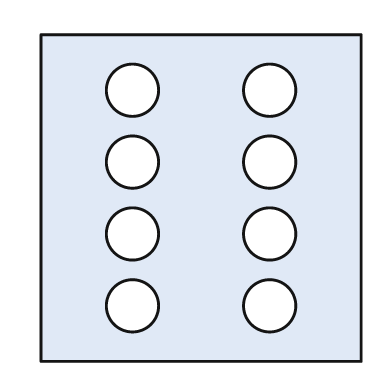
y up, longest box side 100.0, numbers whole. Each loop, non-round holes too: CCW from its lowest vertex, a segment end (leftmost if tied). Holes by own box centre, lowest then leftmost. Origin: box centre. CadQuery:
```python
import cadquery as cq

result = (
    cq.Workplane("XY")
    .moveTo(-49.0, -50.0)
    .lineTo(49.0, -50.0)
    .lineTo(49.0, 50.0)
    .lineTo(-49.0, 50.0)
    .close()
    .moveTo(-21.0, -33.0)
    .circle(8.0)
    .moveTo(21.0, -33.0)
    .circle(8.0)
    .moveTo(-21.0, -11.0)
    .circle(8.0)
    .moveTo(21.0, -11.0)
    .circle(8.0)
    .moveTo(-21.0, 11.0)
    .circle(8.0)
    .moveTo(21.0, 11.0)
    .circle(8.0)
    .moveTo(-21.0, 33.0)
    .circle(8.0)
    .moveTo(21.0, 33.0)
    .circle(8.0)
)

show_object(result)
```